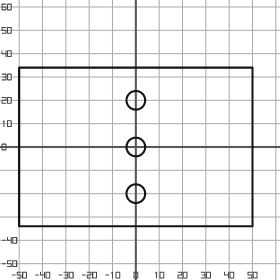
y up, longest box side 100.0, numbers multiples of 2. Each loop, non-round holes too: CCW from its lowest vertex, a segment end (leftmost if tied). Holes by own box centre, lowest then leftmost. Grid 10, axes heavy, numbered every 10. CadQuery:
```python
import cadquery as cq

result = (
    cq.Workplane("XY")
    .moveTo(-50.0, -34.0)
    .lineTo(50.0, -34.0)
    .lineTo(50.0, 34.0)
    .lineTo(-50.0, 34.0)
    .close()
    .moveTo(0.0, -20.0)
    .circle(4.0)
    .moveTo(0.0, 0.0)
    .circle(4.0)
    .moveTo(0.0, 20.0)
    .circle(4.0)
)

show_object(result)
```